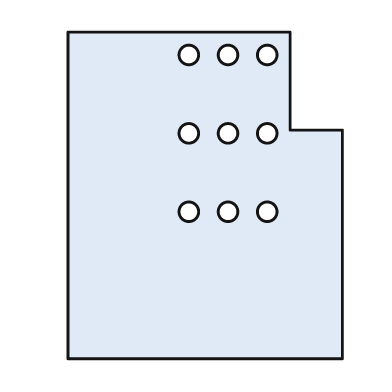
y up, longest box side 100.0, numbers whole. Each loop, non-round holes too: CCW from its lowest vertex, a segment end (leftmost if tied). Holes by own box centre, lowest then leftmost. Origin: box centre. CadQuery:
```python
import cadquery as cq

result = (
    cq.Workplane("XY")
    .moveTo(-42.0, -50.0)
    .lineTo(42.0, -50.0)
    .lineTo(42.0, 20.0)
    .lineTo(26.0, 20.0)
    .lineTo(26.0, 50.0)
    .lineTo(-42.0, 50.0)
    .close()
    .moveTo(-5.0, -5.0)
    .circle(3.0)
    .moveTo(7.0, -5.0)
    .circle(3.0)
    .moveTo(19.0, -5.0)
    .circle(3.0)
    .moveTo(-5.0, 19.0)
    .circle(3.0)
    .moveTo(7.0, 19.0)
    .circle(3.0)
    .moveTo(19.0, 19.0)
    .circle(3.0)
    .moveTo(-5.0, 43.0)
    .circle(3.0)
    .moveTo(7.0, 43.0)
    .circle(3.0)
    .moveTo(19.0, 43.0)
    .circle(3.0)
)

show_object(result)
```